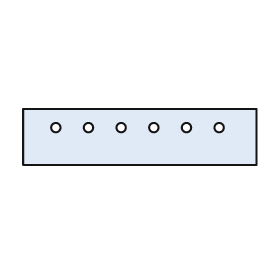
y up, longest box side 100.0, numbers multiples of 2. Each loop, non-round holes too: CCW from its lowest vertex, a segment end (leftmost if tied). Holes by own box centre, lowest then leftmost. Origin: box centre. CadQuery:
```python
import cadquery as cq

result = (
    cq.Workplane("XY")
    .moveTo(-50.0, -12.0)
    .lineTo(50.0, -12.0)
    .lineTo(50.0, 12.0)
    .lineTo(-50.0, 12.0)
    .close()
    .moveTo(-36.0, 4.0)
    .circle(2.0)
    .moveTo(-22.0, 4.0)
    .circle(2.0)
    .moveTo(-8.0, 4.0)
    .circle(2.0)
    .moveTo(6.0, 4.0)
    .circle(2.0)
    .moveTo(20.0, 4.0)
    .circle(2.0)
    .moveTo(34.0, 4.0)
    .circle(2.0)
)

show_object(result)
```